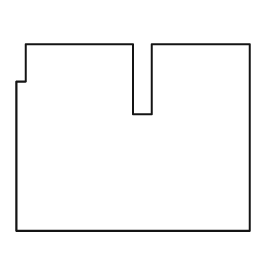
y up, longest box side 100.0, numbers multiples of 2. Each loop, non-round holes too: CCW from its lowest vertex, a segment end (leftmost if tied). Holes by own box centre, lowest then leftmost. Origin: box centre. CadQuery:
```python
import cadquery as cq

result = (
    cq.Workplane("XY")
    .moveTo(-50.0, -40.0)
    .lineTo(50.0, -40.0)
    .lineTo(50.0, 40.0)
    .lineTo(8.0, 40.0)
    .lineTo(8.0, 10.0)
    .lineTo(0.0, 10.0)
    .lineTo(0.0, 40.0)
    .lineTo(-46.0, 40.0)
    .lineTo(-46.0, 24.0)
    .lineTo(-50.0, 24.0)
    .close()
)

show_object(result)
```